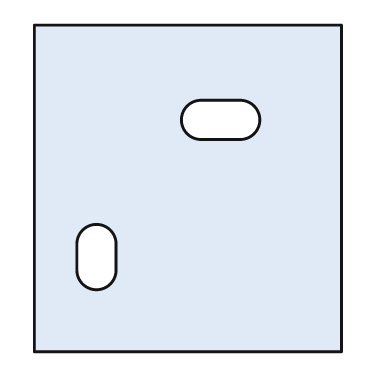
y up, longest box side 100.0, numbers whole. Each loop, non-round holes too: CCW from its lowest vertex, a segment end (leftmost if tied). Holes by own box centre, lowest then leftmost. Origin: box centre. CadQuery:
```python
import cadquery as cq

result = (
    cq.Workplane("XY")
    .moveTo(-47.0, -50.0)
    .lineTo(47.0, -50.0)
    .lineTo(47.0, 50.0)
    .lineTo(-47.0, 50.0)
    .close()
    .moveTo(-34.0, -25.0)
    .threePointArc((-28.0, -31.0), (-22.0, -25.0))
    .lineTo(-22.0, -17.0)
    .threePointArc((-28.0, -11.0), (-34.0, -17.0))
    .close()
    .moveTo(4.0, 15.0)
    .lineTo(16.0, 15.0)
    .threePointArc((22.0, 21.0), (16.0, 27.0))
    .lineTo(4.0, 27.0)
    .threePointArc((-2.0, 21.0), (4.0, 15.0))
    .close()
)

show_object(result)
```